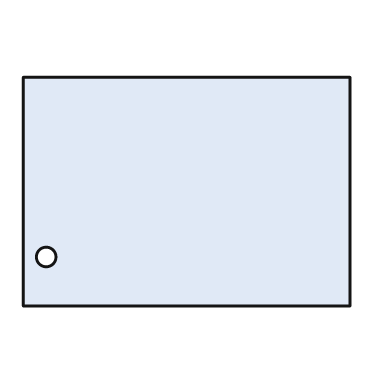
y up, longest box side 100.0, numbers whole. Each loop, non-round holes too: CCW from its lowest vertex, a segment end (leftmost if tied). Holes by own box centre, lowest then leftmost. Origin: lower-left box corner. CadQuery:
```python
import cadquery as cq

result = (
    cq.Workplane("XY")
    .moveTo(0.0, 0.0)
    .lineTo(100.0, 0.0)
    .lineTo(100.0, 70.0)
    .lineTo(0.0, 70.0)
    .close()
    .moveTo(7.0, 15.0)
    .circle(3.0)
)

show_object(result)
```